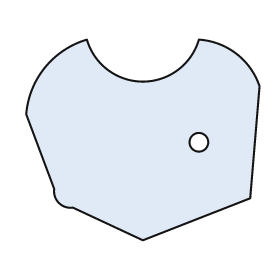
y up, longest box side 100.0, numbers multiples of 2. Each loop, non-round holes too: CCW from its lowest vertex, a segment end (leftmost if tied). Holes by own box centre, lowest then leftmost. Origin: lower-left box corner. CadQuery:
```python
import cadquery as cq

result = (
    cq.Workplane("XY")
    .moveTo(50.0, 0.0)
    .lineTo(96.0, 18.0)
    .lineTo(100.0, 66.0)
    .threePointArc((90.0, 80.0), (74.0, 86.0))
    .threePointArc((50.0, 68.0), (26.0, 86.0))
    .threePointArc((8.0, 74.0), (0.0, 54.0))
    .lineTo(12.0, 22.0)
    .threePointArc((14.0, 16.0), (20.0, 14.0))
    .close()
    .moveTo(74.0, 42.0)
    .circle(4.0)
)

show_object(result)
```